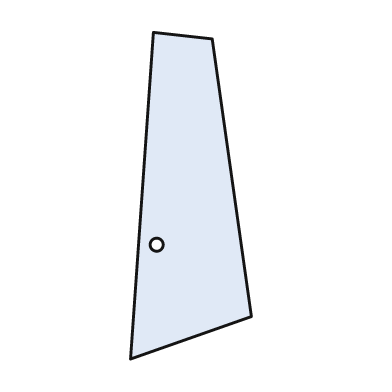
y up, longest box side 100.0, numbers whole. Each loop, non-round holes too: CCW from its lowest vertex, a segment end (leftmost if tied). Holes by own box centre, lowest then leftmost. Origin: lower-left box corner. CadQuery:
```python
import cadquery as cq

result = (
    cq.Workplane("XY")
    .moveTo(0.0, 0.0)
    .lineTo(37.0, 13.0)
    .lineTo(25.0, 98.0)
    .lineTo(7.0, 100.0)
    .close()
    .moveTo(8.0, 35.0)
    .circle(2.0)
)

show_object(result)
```